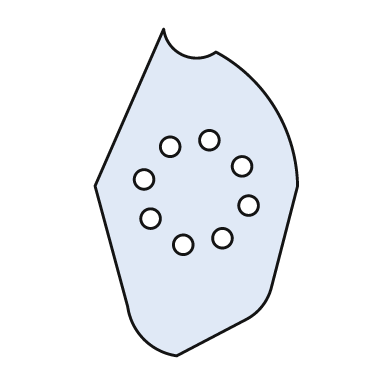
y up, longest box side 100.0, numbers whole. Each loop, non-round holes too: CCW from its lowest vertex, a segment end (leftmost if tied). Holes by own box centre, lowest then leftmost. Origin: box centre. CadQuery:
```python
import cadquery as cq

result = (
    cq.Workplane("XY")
    .moveTo(-6.0, -50.0)
    .lineTo(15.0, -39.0)
    .threePointArc((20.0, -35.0), (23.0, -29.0))
    .lineTo(31.0, 2.0)
    .threePointArc((24.0, 26.0), (6.0, 43.0))
    .threePointArc((-4.0, 42.0), (-10.0, 50.0))
    .lineTo(-31.0, 2.0)
    .lineTo(-21.0, -35.0)
    .threePointArc((-16.0, -45.0), (-6.0, -50.0))
    .close()
    .moveTo(-4.0, -16.0)
    .circle(3.0)
    .moveTo(8.0, -14.0)
    .circle(3.0)
    .moveTo(-14.0, -8.0)
    .circle(3.0)
    .moveTo(16.0, -4.0)
    .circle(3.0)
    .moveTo(-16.0, 4.0)
    .circle(3.0)
    .moveTo(14.0, 8.0)
    .circle(3.0)
    .moveTo(-8.0, 14.0)
    .circle(3.0)
    .moveTo(4.0, 16.0)
    .circle(3.0)
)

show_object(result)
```